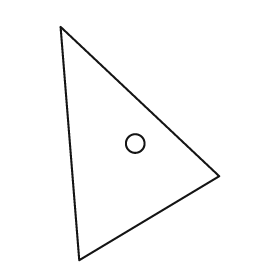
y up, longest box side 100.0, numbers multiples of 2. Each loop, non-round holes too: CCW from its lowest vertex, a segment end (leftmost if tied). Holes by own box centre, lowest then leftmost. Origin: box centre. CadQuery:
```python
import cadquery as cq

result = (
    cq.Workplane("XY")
    .moveTo(-26.0, -50.0)
    .lineTo(34.0, -14.0)
    .lineTo(-34.0, 50.0)
    .close()
    .moveTo(-2.0, 0.0)
    .circle(4.0)
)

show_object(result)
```